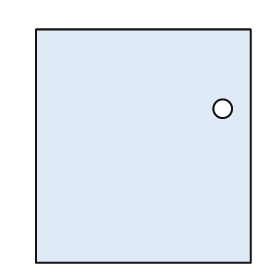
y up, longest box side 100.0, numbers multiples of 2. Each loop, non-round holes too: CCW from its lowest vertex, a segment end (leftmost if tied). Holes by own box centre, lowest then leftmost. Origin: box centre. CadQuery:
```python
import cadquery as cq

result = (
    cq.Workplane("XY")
    .moveTo(-46.0, -50.0)
    .lineTo(46.0, -50.0)
    .lineTo(46.0, 50.0)
    .lineTo(-46.0, 50.0)
    .close()
    .moveTo(34.0, 16.0)
    .circle(4.0)
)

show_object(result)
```